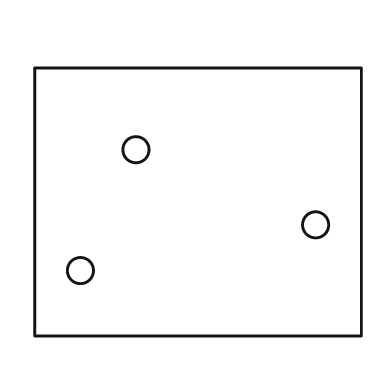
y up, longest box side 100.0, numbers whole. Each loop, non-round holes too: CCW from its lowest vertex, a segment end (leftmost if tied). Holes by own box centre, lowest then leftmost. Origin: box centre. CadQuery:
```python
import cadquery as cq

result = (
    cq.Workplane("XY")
    .moveTo(-50.0, -41.0)
    .lineTo(50.0, -41.0)
    .lineTo(50.0, 41.0)
    .lineTo(-50.0, 41.0)
    .close()
    .moveTo(-36.0, -21.0)
    .circle(4.0)
    .moveTo(36.0, -7.0)
    .circle(4.0)
    .moveTo(-19.0, 16.0)
    .circle(4.0)
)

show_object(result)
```